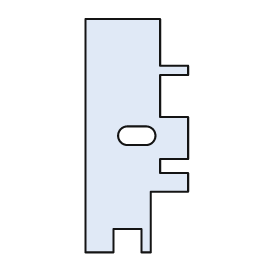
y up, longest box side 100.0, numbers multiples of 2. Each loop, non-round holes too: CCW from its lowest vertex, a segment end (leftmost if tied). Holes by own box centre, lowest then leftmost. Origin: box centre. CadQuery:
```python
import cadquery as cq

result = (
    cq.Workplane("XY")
    .moveTo(-22.0, -50.0)
    .lineTo(-10.0, -50.0)
    .lineTo(-10.0, -40.0)
    .lineTo(2.0, -40.0)
    .lineTo(2.0, -50.0)
    .lineTo(6.0, -50.0)
    .lineTo(6.0, -24.0)
    .lineTo(22.0, -24.0)
    .lineTo(22.0, -16.0)
    .lineTo(10.0, -16.0)
    .lineTo(10.0, -10.0)
    .lineTo(22.0, -10.0)
    .lineTo(22.0, 8.0)
    .lineTo(10.0, 8.0)
    .lineTo(10.0, 26.0)
    .lineTo(22.0, 26.0)
    .lineTo(22.0, 30.0)
    .lineTo(10.0, 30.0)
    .lineTo(10.0, 50.0)
    .lineTo(-22.0, 50.0)
    .close()
    .moveTo(-4.0, -4.0)
    .lineTo(4.0, -4.0)
    .threePointArc((8.0, 0.0), (4.0, 4.0))
    .lineTo(-4.0, 4.0)
    .threePointArc((-8.0, 0.0), (-4.0, -4.0))
    .close()
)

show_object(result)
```